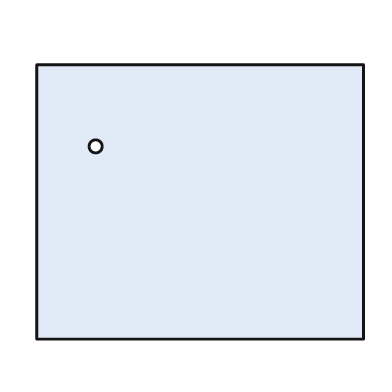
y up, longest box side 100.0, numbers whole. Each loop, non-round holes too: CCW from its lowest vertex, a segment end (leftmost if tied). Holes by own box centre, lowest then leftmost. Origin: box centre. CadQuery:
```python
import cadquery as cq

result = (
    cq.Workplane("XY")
    .moveTo(-50.0, -42.0)
    .lineTo(50.0, -42.0)
    .lineTo(50.0, 42.0)
    .lineTo(-50.0, 42.0)
    .close()
    .moveTo(-32.0, 17.0)
    .circle(2.0)
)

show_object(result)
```